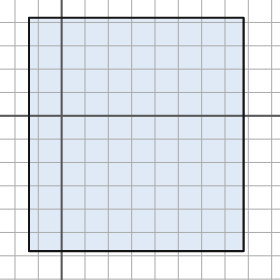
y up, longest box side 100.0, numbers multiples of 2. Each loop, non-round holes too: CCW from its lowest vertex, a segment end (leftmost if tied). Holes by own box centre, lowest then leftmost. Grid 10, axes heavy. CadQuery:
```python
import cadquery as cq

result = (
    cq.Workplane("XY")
    .moveTo(-14.0, -58.0)
    .lineTo(78.0, -58.0)
    .lineTo(78.0, 42.0)
    .lineTo(-14.0, 42.0)
    .close()
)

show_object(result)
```